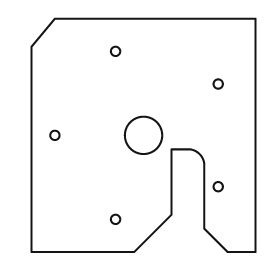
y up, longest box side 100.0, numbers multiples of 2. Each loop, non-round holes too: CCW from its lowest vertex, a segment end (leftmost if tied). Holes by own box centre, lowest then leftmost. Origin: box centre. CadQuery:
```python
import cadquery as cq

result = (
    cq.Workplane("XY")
    .moveTo(-48.0, -50.0)
    .lineTo(-4.0, -50.0)
    .lineTo(12.0, -34.0)
    .lineTo(12.0, -6.0)
    .lineTo(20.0, -6.0)
    .threePointArc((24.0, -8.0), (26.0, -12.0))
    .lineTo(26.0, -40.0)
    .lineTo(36.0, -50.0)
    .lineTo(48.0, -50.0)
    .lineTo(48.0, 50.0)
    .lineTo(-38.0, 50.0)
    .lineTo(-48.0, 38.0)
    .close()
    .moveTo(-12.0, -36.0)
    .circle(2.0)
    .moveTo(32.0, -22.0)
    .circle(2.0)
    .moveTo(-38.0, 0.0)
    .circle(2.0)
    .moveTo(0.0, 0.0)
    .circle(8.0)
    .moveTo(32.0, 22.0)
    .circle(2.0)
    .moveTo(-12.0, 36.0)
    .circle(2.0)
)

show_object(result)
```